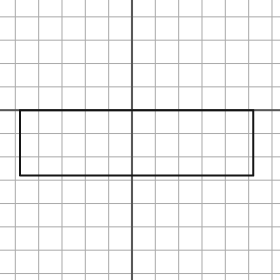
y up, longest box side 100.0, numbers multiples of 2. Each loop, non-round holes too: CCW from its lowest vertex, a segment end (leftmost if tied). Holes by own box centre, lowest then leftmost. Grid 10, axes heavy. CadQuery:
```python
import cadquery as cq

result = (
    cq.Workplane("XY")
    .moveTo(-48.0, -28.0)
    .lineTo(52.0, -28.0)
    .lineTo(52.0, 0.0)
    .lineTo(-48.0, 0.0)
    .close()
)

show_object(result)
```